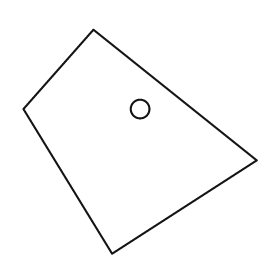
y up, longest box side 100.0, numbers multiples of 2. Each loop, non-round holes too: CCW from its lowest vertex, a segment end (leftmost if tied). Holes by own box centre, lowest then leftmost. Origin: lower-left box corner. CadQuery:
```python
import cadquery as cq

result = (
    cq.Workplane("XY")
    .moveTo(38.0, 0.0)
    .lineTo(100.0, 40.0)
    .lineTo(30.0, 96.0)
    .lineTo(0.0, 62.0)
    .close()
    .moveTo(50.0, 62.0)
    .circle(4.0)
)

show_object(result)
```